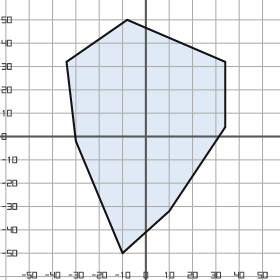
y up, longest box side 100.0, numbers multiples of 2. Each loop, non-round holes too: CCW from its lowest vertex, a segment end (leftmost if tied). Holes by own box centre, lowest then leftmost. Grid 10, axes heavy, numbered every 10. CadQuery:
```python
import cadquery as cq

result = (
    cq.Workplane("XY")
    .moveTo(-10.0, -50.0)
    .lineTo(10.0, -32.0)
    .lineTo(34.0, 4.0)
    .lineTo(34.0, 32.0)
    .lineTo(-8.0, 50.0)
    .lineTo(-34.0, 32.0)
    .lineTo(-30.0, -2.0)
    .close()
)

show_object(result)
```